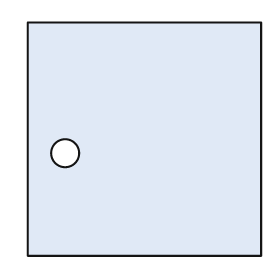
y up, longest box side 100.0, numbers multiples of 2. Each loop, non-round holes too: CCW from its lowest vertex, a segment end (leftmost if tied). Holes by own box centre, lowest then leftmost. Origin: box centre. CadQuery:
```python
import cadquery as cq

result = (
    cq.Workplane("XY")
    .moveTo(-50.0, -50.0)
    .lineTo(50.0, -50.0)
    .lineTo(50.0, 50.0)
    .lineTo(-50.0, 50.0)
    .close()
    .moveTo(-34.0, -6.0)
    .circle(6.0)
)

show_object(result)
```